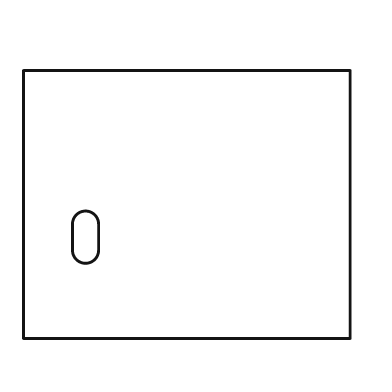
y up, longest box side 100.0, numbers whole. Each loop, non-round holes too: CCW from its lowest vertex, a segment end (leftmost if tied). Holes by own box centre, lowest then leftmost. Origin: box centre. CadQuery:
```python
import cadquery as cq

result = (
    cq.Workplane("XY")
    .moveTo(-50.0, -41.0)
    .lineTo(50.0, -41.0)
    .lineTo(50.0, 41.0)
    .lineTo(-50.0, 41.0)
    .close()
    .moveTo(-35.0, -14.0)
    .threePointArc((-31.0, -18.0), (-27.0, -14.0))
    .lineTo(-27.0, -6.0)
    .threePointArc((-31.0, -2.0), (-35.0, -6.0))
    .close()
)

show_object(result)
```